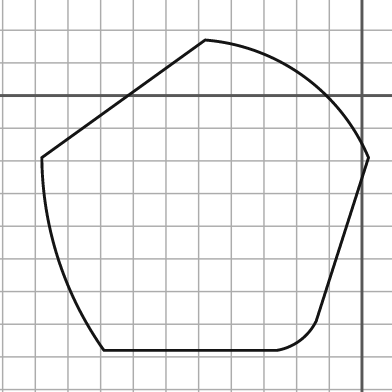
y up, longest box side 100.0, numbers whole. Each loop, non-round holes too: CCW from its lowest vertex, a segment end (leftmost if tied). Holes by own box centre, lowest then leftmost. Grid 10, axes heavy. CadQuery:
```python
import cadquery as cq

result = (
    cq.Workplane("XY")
    .moveTo(-79.0, -78.0)
    .lineTo(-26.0, -78.0)
    .threePointArc((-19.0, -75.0), (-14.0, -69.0))
    .lineTo(2.0, -19.0)
    .threePointArc((-18.0, 6.0), (-48.0, 17.0))
    .lineTo(-98.0, -19.0)
    .threePointArc((-93.0, -50.0), (-79.0, -78.0))
    .close()
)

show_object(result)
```